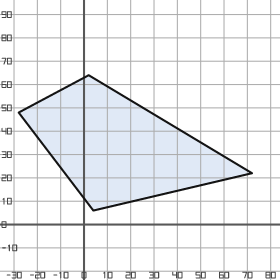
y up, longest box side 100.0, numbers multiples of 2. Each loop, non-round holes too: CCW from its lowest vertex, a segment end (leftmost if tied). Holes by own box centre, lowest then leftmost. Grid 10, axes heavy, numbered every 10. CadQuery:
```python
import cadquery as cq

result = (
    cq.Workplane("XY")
    .moveTo(4.0, 6.0)
    .lineTo(72.0, 22.0)
    .lineTo(2.0, 64.0)
    .lineTo(-28.0, 48.0)
    .close()
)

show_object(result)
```